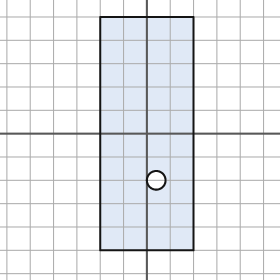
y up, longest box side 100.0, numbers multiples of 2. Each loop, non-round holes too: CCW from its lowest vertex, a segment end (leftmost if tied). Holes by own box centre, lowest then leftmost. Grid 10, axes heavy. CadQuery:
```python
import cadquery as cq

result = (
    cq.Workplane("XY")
    .moveTo(-20.0, -50.0)
    .lineTo(20.0, -50.0)
    .lineTo(20.0, 50.0)
    .lineTo(-20.0, 50.0)
    .close()
    .moveTo(4.0, -20.0)
    .circle(4.0)
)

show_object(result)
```